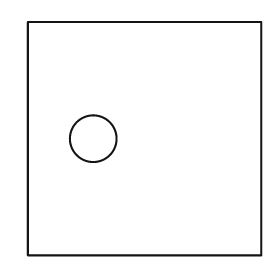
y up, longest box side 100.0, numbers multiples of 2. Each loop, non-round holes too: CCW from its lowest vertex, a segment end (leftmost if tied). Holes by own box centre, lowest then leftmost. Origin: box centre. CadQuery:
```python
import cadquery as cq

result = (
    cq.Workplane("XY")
    .moveTo(-50.0, -50.0)
    .lineTo(50.0, -50.0)
    .lineTo(50.0, 50.0)
    .lineTo(-50.0, 50.0)
    .close()
    .moveTo(-22.0, 0.0)
    .circle(10.0)
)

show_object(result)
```